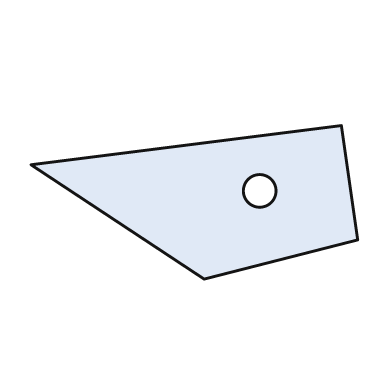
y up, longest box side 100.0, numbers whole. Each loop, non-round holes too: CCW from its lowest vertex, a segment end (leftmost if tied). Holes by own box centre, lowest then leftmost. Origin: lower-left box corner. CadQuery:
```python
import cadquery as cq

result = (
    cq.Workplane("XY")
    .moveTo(53.0, 0.0)
    .lineTo(100.0, 12.0)
    .lineTo(95.0, 47.0)
    .lineTo(0.0, 35.0)
    .close()
    .moveTo(70.0, 27.0)
    .circle(5.0)
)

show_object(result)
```